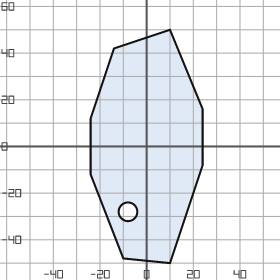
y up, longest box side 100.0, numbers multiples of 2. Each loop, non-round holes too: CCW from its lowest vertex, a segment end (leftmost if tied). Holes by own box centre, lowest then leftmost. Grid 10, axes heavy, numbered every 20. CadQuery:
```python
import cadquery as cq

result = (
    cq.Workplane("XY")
    .moveTo(10.0, -50.0)
    .lineTo(24.0, -8.0)
    .lineTo(24.0, 16.0)
    .lineTo(10.0, 50.0)
    .lineTo(-14.0, 42.0)
    .lineTo(-24.0, 12.0)
    .lineTo(-24.0, -12.0)
    .lineTo(-10.0, -48.0)
    .close()
    .moveTo(-8.0, -28.0)
    .circle(4.0)
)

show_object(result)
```